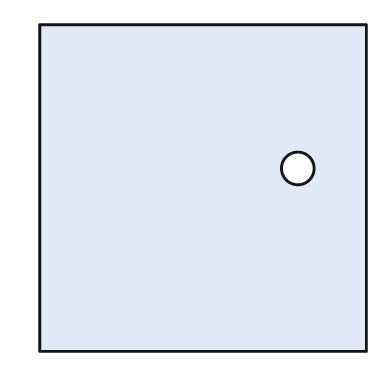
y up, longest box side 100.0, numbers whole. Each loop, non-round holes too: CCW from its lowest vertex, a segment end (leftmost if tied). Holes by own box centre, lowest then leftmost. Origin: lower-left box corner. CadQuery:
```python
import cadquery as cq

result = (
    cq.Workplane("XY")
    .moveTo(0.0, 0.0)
    .lineTo(100.0, 0.0)
    .lineTo(100.0, 100.0)
    .lineTo(0.0, 100.0)
    .close()
    .moveTo(79.0, 56.0)
    .circle(5.0)
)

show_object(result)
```